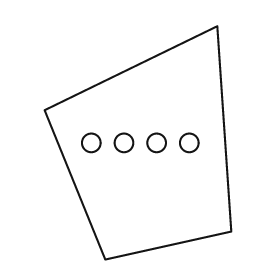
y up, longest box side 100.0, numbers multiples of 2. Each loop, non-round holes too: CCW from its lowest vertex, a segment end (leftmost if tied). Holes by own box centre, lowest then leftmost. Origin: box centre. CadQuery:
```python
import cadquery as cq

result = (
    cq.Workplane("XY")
    .moveTo(-14.0, -50.0)
    .lineTo(40.0, -38.0)
    .lineTo(34.0, 50.0)
    .lineTo(-40.0, 14.0)
    .close()
    .moveTo(-20.0, 0.0)
    .circle(4.0)
    .moveTo(-6.0, 0.0)
    .circle(4.0)
    .moveTo(8.0, 0.0)
    .circle(4.0)
    .moveTo(22.0, 0.0)
    .circle(4.0)
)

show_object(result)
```